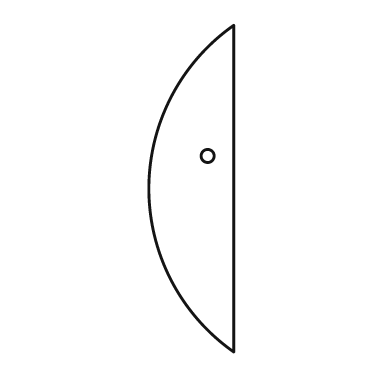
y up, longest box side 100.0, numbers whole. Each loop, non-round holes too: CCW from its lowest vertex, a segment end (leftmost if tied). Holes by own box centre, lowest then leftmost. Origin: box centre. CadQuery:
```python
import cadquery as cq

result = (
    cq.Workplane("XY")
    .moveTo(13.0, -50.0)
    .lineTo(13.0, 50.0)
    .threePointArc((-13.0, 0.0), (13.0, -50.0))
    .close()
    .moveTo(5.0, 10.0)
    .circle(2.0)
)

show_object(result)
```